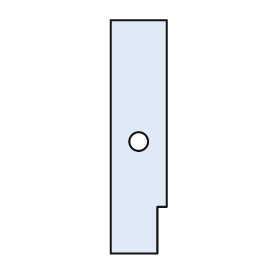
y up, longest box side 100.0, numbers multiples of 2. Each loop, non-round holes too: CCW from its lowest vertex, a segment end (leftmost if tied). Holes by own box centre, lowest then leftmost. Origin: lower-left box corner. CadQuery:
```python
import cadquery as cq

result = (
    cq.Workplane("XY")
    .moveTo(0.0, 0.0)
    .lineTo(20.0, 0.0)
    .lineTo(20.0, 20.0)
    .lineTo(24.0, 20.0)
    .lineTo(24.0, 100.0)
    .lineTo(0.0, 100.0)
    .close()
    .moveTo(12.0, 48.0)
    .circle(4.0)
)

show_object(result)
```